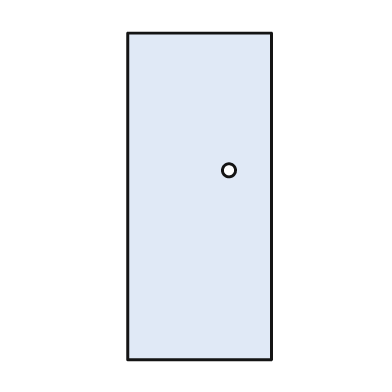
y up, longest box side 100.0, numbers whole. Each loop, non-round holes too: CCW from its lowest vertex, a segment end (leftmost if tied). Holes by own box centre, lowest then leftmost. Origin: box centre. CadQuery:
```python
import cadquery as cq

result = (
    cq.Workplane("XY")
    .moveTo(-22.0, -50.0)
    .lineTo(22.0, -50.0)
    .lineTo(22.0, 50.0)
    .lineTo(-22.0, 50.0)
    .close()
    .moveTo(9.0, 8.0)
    .circle(2.0)
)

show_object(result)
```